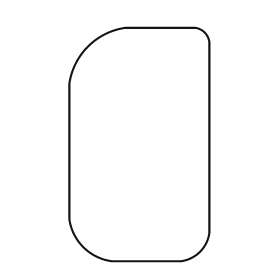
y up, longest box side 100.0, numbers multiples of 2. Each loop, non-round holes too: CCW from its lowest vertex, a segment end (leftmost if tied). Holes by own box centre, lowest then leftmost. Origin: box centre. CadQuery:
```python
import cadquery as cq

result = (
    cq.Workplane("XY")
    .moveTo(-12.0, -50.0)
    .lineTo(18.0, -50.0)
    .threePointArc((26.0, -46.0), (30.0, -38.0))
    .lineTo(30.0, 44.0)
    .threePointArc((28.0, 48.0), (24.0, 50.0))
    .lineTo(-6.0, 50.0)
    .threePointArc((-22.0, 42.0), (-30.0, 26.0))
    .lineTo(-30.0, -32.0)
    .threePointArc((-24.0, -44.0), (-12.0, -50.0))
    .close()
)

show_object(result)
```